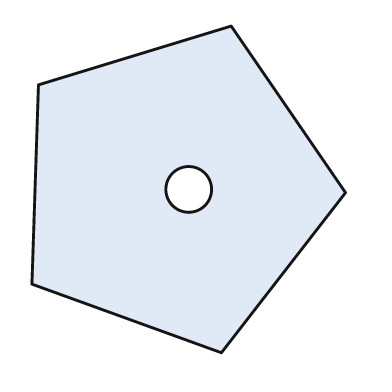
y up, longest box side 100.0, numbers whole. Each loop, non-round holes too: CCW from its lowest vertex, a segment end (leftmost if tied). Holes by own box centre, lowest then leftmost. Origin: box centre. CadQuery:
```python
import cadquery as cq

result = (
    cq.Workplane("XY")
    .moveTo(10.0, -50.0)
    .lineTo(48.0, -1.0)
    .lineTo(13.0, 50.0)
    .lineTo(-46.0, 32.0)
    .lineTo(-48.0, -29.0)
    .close()
    .moveTo(0.0, 0.0)
    .circle(7.0)
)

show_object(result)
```